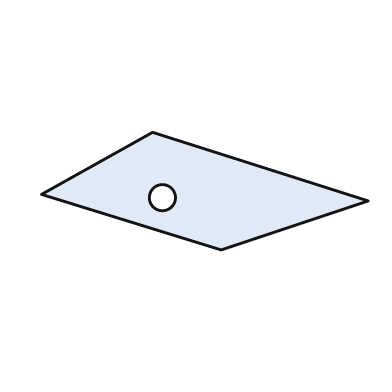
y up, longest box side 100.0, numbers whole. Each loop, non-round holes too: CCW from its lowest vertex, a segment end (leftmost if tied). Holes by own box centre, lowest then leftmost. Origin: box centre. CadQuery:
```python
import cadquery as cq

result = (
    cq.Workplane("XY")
    .moveTo(5.0, -18.0)
    .lineTo(50.0, -3.0)
    .lineTo(-16.0, 18.0)
    .lineTo(-50.0, -1.0)
    .close()
    .moveTo(-13.0, -2.0)
    .circle(4.0)
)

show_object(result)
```